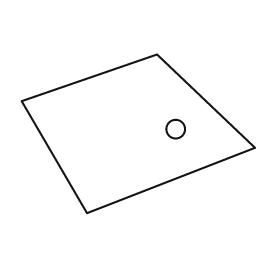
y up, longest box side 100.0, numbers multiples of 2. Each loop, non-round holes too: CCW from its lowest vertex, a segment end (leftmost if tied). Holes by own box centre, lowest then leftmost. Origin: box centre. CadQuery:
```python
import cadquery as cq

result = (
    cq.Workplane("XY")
    .moveTo(-22.0, -34.0)
    .lineTo(50.0, -6.0)
    .lineTo(8.0, 34.0)
    .lineTo(-50.0, 14.0)
    .close()
    .moveTo(16.0, 2.0)
    .circle(4.0)
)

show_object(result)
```